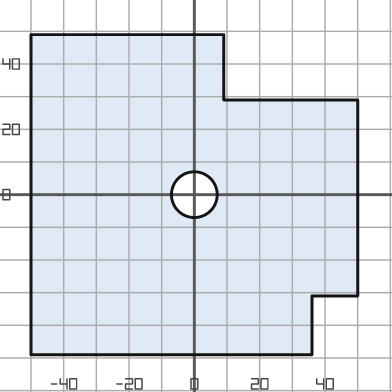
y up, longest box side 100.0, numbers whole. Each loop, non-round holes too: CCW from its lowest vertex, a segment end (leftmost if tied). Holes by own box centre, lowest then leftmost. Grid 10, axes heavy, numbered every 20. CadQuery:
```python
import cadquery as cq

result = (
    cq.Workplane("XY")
    .moveTo(-50.0, -49.0)
    .lineTo(36.0, -49.0)
    .lineTo(36.0, -31.0)
    .lineTo(50.0, -31.0)
    .lineTo(50.0, 29.0)
    .lineTo(9.0, 29.0)
    .lineTo(9.0, 49.0)
    .lineTo(-50.0, 49.0)
    .close()
    .moveTo(0.0, 0.0)
    .circle(7.0)
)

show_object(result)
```